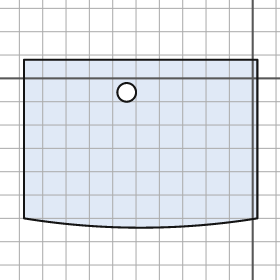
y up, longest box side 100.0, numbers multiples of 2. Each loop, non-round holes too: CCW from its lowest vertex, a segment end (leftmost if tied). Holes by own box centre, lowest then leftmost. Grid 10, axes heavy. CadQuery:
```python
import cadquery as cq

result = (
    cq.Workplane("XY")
    .moveTo(-98.0, -60.0)
    .threePointArc((-48.0, -64.0), (2.0, -60.0))
    .lineTo(2.0, 8.0)
    .lineTo(-98.0, 8.0)
    .close()
    .moveTo(-54.0, -6.0)
    .circle(4.0)
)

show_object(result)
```